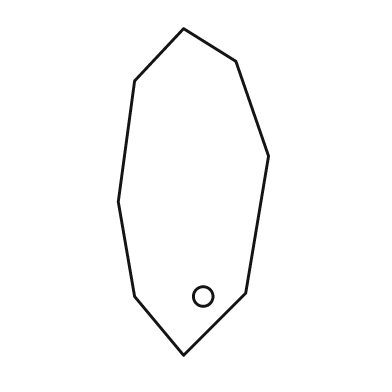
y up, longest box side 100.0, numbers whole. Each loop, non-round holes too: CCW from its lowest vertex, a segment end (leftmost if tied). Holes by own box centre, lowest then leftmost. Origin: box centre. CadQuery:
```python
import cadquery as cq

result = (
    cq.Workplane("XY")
    .moveTo(-3.0, -50.0)
    .lineTo(16.0, -31.0)
    .lineTo(23.0, 11.0)
    .lineTo(13.0, 40.0)
    .lineTo(-3.0, 50.0)
    .lineTo(-18.0, 34.0)
    .lineTo(-23.0, -3.0)
    .lineTo(-18.0, -32.0)
    .close()
    .moveTo(3.0, -32.0)
    .circle(3.0)
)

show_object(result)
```